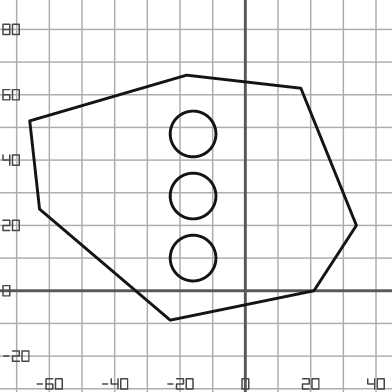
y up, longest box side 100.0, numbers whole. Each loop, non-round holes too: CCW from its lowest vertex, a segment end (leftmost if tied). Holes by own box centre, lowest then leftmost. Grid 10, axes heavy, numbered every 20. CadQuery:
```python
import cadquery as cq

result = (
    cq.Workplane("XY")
    .moveTo(-23.0, -9.0)
    .lineTo(21.0, 0.0)
    .lineTo(34.0, 20.0)
    .lineTo(17.0, 62.0)
    .lineTo(-18.0, 66.0)
    .lineTo(-66.0, 52.0)
    .lineTo(-63.0, 25.0)
    .close()
    .moveTo(-16.0, 10.0)
    .circle(7.0)
    .moveTo(-16.0, 29.0)
    .circle(7.0)
    .moveTo(-16.0, 48.0)
    .circle(7.0)
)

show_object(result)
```